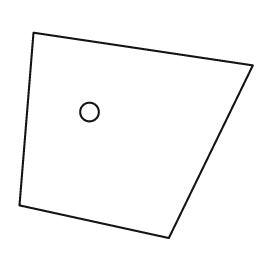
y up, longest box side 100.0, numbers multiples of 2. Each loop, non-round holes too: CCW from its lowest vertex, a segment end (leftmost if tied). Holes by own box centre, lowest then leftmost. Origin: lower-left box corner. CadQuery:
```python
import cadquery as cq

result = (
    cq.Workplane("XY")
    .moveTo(64.0, 0.0)
    .lineTo(100.0, 74.0)
    .lineTo(6.0, 88.0)
    .lineTo(0.0, 14.0)
    .close()
    .moveTo(30.0, 54.0)
    .circle(4.0)
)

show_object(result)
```